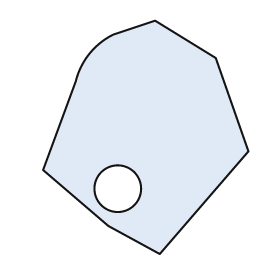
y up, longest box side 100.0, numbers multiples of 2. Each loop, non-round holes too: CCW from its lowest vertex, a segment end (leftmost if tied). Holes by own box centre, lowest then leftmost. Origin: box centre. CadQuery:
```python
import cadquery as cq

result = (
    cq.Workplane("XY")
    .moveTo(6.0, -50.0)
    .lineTo(44.0, -6.0)
    .lineTo(30.0, 34.0)
    .lineTo(4.0, 50.0)
    .lineTo(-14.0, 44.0)
    .threePointArc((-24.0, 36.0), (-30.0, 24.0))
    .lineTo(-44.0, -14.0)
    .lineTo(-16.0, -38.0)
    .close()
    .moveTo(-12.0, -22.0)
    .circle(10.0)
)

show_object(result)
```